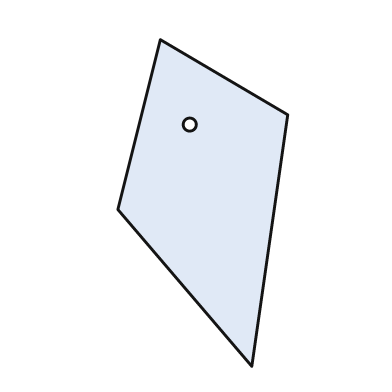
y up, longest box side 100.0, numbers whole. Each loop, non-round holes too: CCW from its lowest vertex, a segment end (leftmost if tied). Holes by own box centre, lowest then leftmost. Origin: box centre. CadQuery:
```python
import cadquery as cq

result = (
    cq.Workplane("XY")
    .moveTo(15.0, -50.0)
    .lineTo(26.0, 27.0)
    .lineTo(-13.0, 50.0)
    .lineTo(-26.0, -2.0)
    .close()
    .moveTo(-4.0, 24.0)
    .circle(2.0)
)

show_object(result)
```